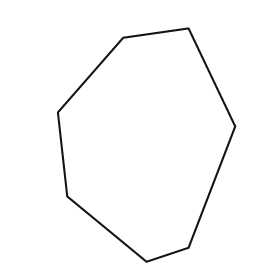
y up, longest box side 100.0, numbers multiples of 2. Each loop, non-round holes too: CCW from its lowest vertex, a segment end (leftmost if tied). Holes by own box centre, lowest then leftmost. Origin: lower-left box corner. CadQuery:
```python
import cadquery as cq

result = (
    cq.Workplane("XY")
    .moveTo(38.0, 0.0)
    .lineTo(56.0, 6.0)
    .lineTo(76.0, 58.0)
    .lineTo(56.0, 100.0)
    .lineTo(28.0, 96.0)
    .lineTo(0.0, 64.0)
    .lineTo(4.0, 28.0)
    .close()
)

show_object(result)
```